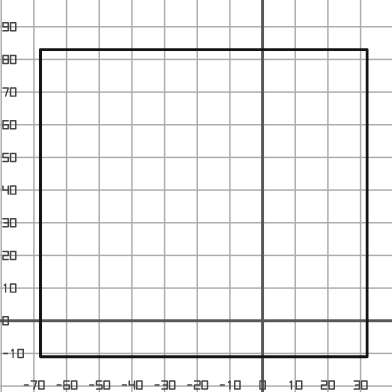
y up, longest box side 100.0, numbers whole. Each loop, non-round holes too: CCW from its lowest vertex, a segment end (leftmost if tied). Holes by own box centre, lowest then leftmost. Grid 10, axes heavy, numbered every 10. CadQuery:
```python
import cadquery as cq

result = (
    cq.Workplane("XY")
    .moveTo(-68.0, -11.0)
    .lineTo(32.0, -11.0)
    .lineTo(32.0, 83.0)
    .lineTo(-68.0, 83.0)
    .close()
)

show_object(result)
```